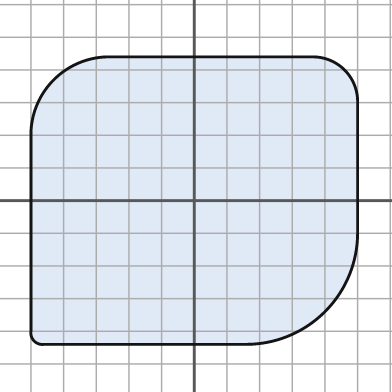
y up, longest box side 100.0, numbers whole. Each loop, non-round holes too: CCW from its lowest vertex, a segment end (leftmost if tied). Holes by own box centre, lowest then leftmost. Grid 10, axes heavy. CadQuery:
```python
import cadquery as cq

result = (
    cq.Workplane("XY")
    .moveTo(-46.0, -44.0)
    .lineTo(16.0, -44.0)
    .threePointArc((40.0, -34.0), (50.0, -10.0))
    .lineTo(50.0, 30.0)
    .threePointArc((46.0, 40.0), (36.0, 44.0))
    .lineTo(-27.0, 44.0)
    .threePointArc((-43.0, 37.0), (-50.0, 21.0))
    .lineTo(-50.0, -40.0)
    .threePointArc((-49.0, -43.0), (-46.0, -44.0))
    .close()
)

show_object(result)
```